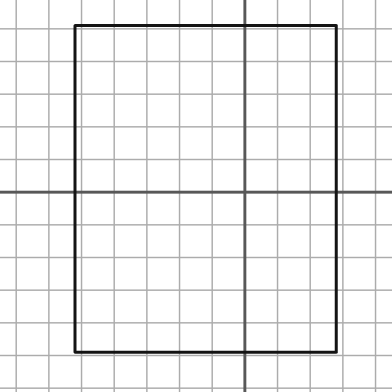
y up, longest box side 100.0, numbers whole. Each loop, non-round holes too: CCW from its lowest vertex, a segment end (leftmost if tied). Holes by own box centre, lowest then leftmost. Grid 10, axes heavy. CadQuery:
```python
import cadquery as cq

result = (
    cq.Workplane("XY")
    .moveTo(-52.0, -49.0)
    .lineTo(28.0, -49.0)
    .lineTo(28.0, 51.0)
    .lineTo(-52.0, 51.0)
    .close()
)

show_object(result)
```